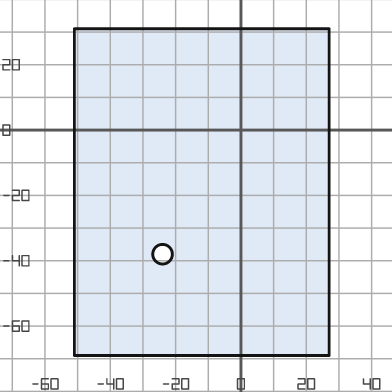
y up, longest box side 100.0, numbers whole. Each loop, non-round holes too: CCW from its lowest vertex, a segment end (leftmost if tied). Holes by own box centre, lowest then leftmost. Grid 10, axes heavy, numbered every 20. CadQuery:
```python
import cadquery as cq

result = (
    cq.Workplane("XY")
    .moveTo(-51.0, -69.0)
    .lineTo(27.0, -69.0)
    .lineTo(27.0, 31.0)
    .lineTo(-51.0, 31.0)
    .close()
    .moveTo(-24.0, -38.0)
    .circle(3.0)
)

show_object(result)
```